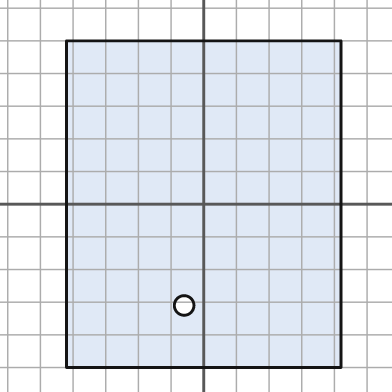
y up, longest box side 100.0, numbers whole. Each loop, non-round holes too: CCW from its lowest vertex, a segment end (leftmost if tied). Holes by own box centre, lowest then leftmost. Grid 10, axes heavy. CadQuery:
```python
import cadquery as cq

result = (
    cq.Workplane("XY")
    .moveTo(-42.0, -50.0)
    .lineTo(42.0, -50.0)
    .lineTo(42.0, 50.0)
    .lineTo(-42.0, 50.0)
    .close()
    .moveTo(-6.0, -31.0)
    .circle(3.0)
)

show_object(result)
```